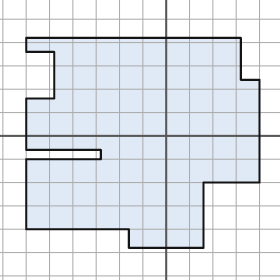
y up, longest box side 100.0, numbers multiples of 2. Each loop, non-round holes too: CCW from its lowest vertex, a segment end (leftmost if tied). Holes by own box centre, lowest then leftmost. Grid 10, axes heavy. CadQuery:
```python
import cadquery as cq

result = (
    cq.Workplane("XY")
    .moveTo(-16.0, -48.0)
    .lineTo(16.0, -48.0)
    .lineTo(16.0, -20.0)
    .lineTo(40.0, -20.0)
    .lineTo(40.0, 24.0)
    .lineTo(32.0, 24.0)
    .lineTo(32.0, 42.0)
    .lineTo(-60.0, 42.0)
    .lineTo(-60.0, 36.0)
    .lineTo(-48.0, 36.0)
    .lineTo(-48.0, 16.0)
    .lineTo(-60.0, 16.0)
    .lineTo(-60.0, -6.0)
    .lineTo(-28.0, -6.0)
    .lineTo(-28.0, -10.0)
    .lineTo(-60.0, -10.0)
    .lineTo(-60.0, -40.0)
    .lineTo(-16.0, -40.0)
    .close()
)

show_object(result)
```